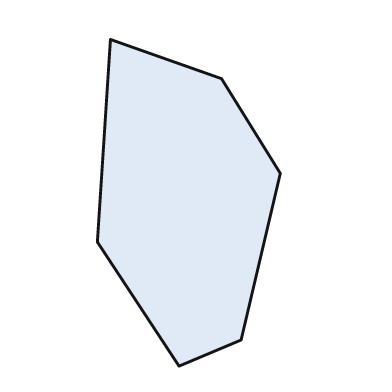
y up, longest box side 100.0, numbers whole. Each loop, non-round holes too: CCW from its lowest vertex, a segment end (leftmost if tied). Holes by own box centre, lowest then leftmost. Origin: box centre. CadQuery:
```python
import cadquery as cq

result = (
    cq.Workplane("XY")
    .moveTo(-3.0, -50.0)
    .lineTo(16.0, -42.0)
    .lineTo(28.0, 9.0)
    .lineTo(10.0, 38.0)
    .lineTo(-24.0, 50.0)
    .lineTo(-28.0, -12.0)
    .close()
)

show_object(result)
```